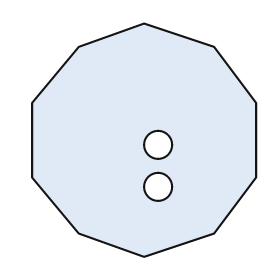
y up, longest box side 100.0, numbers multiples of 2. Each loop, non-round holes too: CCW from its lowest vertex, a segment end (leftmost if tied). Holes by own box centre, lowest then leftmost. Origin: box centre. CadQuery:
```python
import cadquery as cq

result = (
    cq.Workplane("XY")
    .moveTo(0.0, -50.0)
    .lineTo(30.0, -40.0)
    .lineTo(48.0, -16.0)
    .lineTo(48.0, 16.0)
    .lineTo(30.0, 40.0)
    .lineTo(0.0, 50.0)
    .lineTo(-28.0, 40.0)
    .lineTo(-48.0, 16.0)
    .lineTo(-48.0, -16.0)
    .lineTo(-28.0, -40.0)
    .close()
    .moveTo(6.0, -20.0)
    .circle(6.0)
    .moveTo(6.0, -2.0)
    .circle(6.0)
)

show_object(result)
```